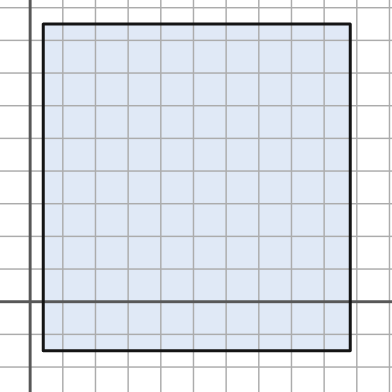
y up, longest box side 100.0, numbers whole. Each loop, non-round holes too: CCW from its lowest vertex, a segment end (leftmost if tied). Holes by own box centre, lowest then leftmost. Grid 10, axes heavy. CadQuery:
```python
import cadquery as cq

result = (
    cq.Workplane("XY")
    .moveTo(4.0, -15.0)
    .lineTo(98.0, -15.0)
    .lineTo(98.0, 85.0)
    .lineTo(4.0, 85.0)
    .close()
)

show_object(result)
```